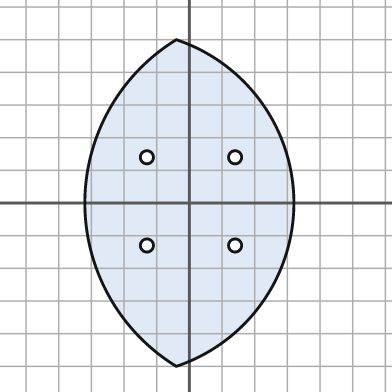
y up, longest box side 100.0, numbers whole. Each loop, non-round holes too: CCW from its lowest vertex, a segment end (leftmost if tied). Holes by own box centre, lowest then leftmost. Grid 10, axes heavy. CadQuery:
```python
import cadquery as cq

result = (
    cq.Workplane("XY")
    .moveTo(-4.0, -50.0)
    .threePointArc((32.0, 0.0), (-4.0, 50.0))
    .threePointArc((-32.0, 0.0), (-4.0, -50.0))
    .close()
    .moveTo(-13.0, -13.0)
    .circle(2.0)
    .moveTo(14.0, -13.0)
    .circle(2.0)
    .moveTo(-13.0, 14.0)
    .circle(2.0)
    .moveTo(14.0, 14.0)
    .circle(2.0)
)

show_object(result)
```